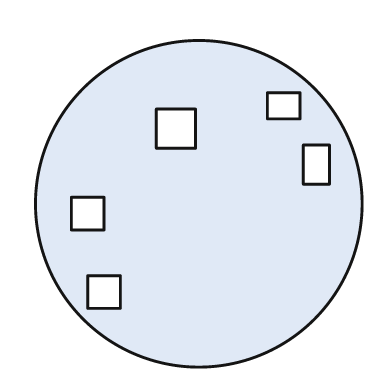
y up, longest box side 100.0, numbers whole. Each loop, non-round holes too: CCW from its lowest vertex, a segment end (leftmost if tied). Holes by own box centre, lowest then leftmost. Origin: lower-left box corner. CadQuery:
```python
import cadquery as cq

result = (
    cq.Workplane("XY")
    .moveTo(50.0, 50.0)
    .circle(50.0)
    .moveTo(16.0, 18.0)
    .lineTo(26.0, 18.0)
    .lineTo(26.0, 28.0)
    .lineTo(16.0, 28.0)
    .close()
    .moveTo(11.0, 42.0)
    .lineTo(21.0, 42.0)
    .lineTo(21.0, 52.0)
    .lineTo(11.0, 52.0)
    .close()
    .moveTo(82.0, 56.0)
    .lineTo(90.0, 56.0)
    .lineTo(90.0, 68.0)
    .lineTo(82.0, 68.0)
    .close()
    .moveTo(37.0, 67.0)
    .lineTo(49.0, 67.0)
    .lineTo(49.0, 79.0)
    .lineTo(37.0, 79.0)
    .close()
    .moveTo(71.0, 76.0)
    .lineTo(81.0, 76.0)
    .lineTo(81.0, 84.0)
    .lineTo(71.0, 84.0)
    .close()
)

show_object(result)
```